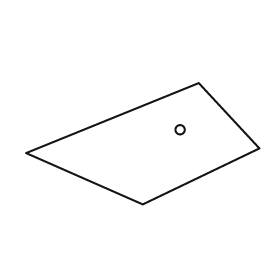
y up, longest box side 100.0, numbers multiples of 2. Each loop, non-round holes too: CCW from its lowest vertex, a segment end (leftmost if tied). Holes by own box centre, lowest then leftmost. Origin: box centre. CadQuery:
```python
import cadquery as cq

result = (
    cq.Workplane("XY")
    .moveTo(0.0, -26.0)
    .lineTo(50.0, -2.0)
    .lineTo(24.0, 26.0)
    .lineTo(-50.0, -4.0)
    .close()
    .moveTo(16.0, 6.0)
    .circle(2.0)
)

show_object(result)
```